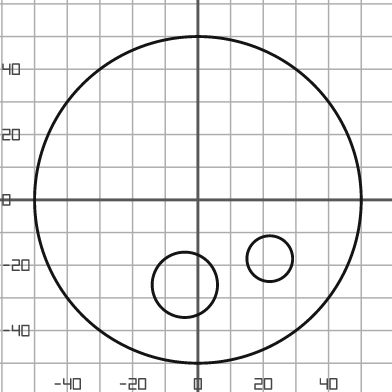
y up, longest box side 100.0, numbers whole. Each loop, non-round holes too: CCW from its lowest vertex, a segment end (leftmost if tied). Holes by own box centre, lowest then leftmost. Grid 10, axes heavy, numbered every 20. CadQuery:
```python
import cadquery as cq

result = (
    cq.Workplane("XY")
    .moveTo(0.0, 0.0)
    .circle(50.0)
    .moveTo(-4.0, -26.0)
    .circle(10.0)
    .moveTo(22.0, -18.0)
    .circle(7.0)
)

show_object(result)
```